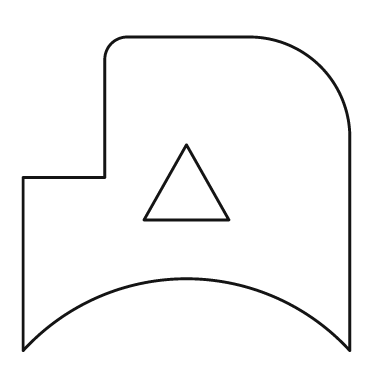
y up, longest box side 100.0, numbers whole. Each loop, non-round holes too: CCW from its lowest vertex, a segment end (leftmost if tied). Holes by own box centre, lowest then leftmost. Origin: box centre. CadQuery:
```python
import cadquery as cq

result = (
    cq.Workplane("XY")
    .moveTo(-50.0, -48.0)
    .threePointArc((0.0, -26.0), (50.0, -48.0))
    .lineTo(50.0, 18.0)
    .threePointArc((41.0, 39.0), (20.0, 48.0))
    .lineTo(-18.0, 48.0)
    .threePointArc((-23.0, 46.0), (-25.0, 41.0))
    .lineTo(-25.0, 5.0)
    .lineTo(-50.0, 5.0)
    .close()
    .moveTo(-13.0, -8.0)
    .lineTo(13.0, -8.0)
    .lineTo(0.0, 15.0)
    .close()
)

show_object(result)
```